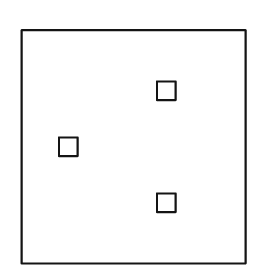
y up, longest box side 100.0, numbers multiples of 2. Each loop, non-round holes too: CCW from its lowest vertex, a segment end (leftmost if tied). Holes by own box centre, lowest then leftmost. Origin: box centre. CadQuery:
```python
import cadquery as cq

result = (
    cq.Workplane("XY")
    .moveTo(-48.0, -50.0)
    .lineTo(48.0, -50.0)
    .lineTo(48.0, 50.0)
    .lineTo(-48.0, 50.0)
    .close()
    .moveTo(10.0, -28.0)
    .lineTo(18.0, -28.0)
    .lineTo(18.0, -20.0)
    .lineTo(10.0, -20.0)
    .close()
    .moveTo(-32.0, -4.0)
    .lineTo(-24.0, -4.0)
    .lineTo(-24.0, 4.0)
    .lineTo(-32.0, 4.0)
    .close()
    .moveTo(10.0, 20.0)
    .lineTo(18.0, 20.0)
    .lineTo(18.0, 28.0)
    .lineTo(10.0, 28.0)
    .close()
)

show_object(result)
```